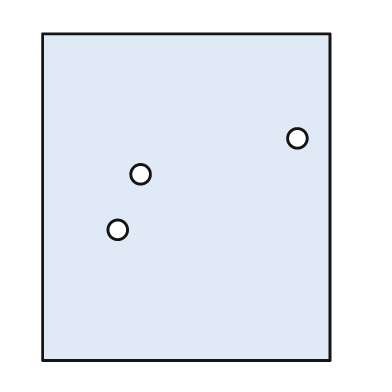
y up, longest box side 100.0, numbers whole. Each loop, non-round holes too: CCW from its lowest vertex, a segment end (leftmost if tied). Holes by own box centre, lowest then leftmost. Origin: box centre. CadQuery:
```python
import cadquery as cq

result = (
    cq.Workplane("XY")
    .moveTo(-44.0, -50.0)
    .lineTo(44.0, -50.0)
    .lineTo(44.0, 50.0)
    .lineTo(-44.0, 50.0)
    .close()
    .moveTo(-21.0, -10.0)
    .circle(3.0)
    .moveTo(-14.0, 7.0)
    .circle(3.0)
    .moveTo(34.0, 18.0)
    .circle(3.0)
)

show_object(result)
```